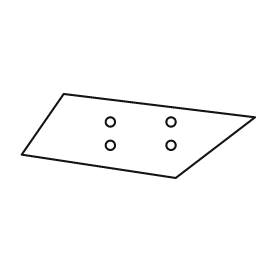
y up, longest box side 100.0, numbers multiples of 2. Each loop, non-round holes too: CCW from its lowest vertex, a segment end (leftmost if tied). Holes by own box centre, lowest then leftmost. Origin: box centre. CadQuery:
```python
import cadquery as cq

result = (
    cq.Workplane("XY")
    .moveTo(16.0, -18.0)
    .lineTo(50.0, 8.0)
    .lineTo(-32.0, 18.0)
    .lineTo(-50.0, -8.0)
    .close()
    .moveTo(-12.0, -4.0)
    .circle(2.0)
    .moveTo(14.0, -4.0)
    .circle(2.0)
    .moveTo(-12.0, 6.0)
    .circle(2.0)
    .moveTo(14.0, 6.0)
    .circle(2.0)
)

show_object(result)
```